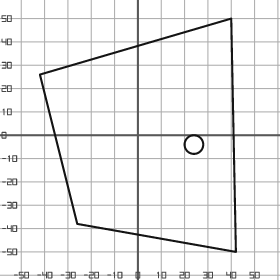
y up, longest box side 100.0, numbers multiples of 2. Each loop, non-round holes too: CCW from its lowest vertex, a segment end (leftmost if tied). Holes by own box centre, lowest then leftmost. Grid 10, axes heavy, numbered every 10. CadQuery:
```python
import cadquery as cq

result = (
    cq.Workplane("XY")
    .moveTo(42.0, -50.0)
    .lineTo(40.0, 50.0)
    .lineTo(-42.0, 26.0)
    .lineTo(-26.0, -38.0)
    .close()
    .moveTo(24.0, -4.0)
    .circle(4.0)
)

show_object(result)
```